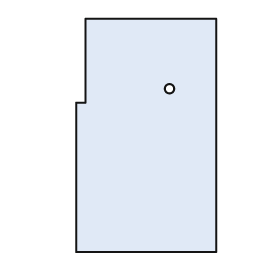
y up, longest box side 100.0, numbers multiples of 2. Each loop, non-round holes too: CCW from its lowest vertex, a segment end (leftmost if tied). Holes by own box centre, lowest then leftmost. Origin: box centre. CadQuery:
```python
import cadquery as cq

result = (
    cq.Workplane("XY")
    .moveTo(-30.0, -50.0)
    .lineTo(30.0, -50.0)
    .lineTo(30.0, 50.0)
    .lineTo(-26.0, 50.0)
    .lineTo(-26.0, 14.0)
    .lineTo(-30.0, 14.0)
    .close()
    .moveTo(10.0, 20.0)
    .circle(2.0)
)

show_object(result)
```